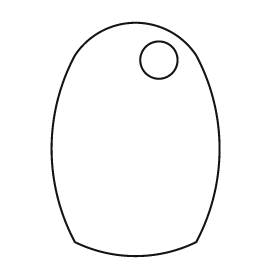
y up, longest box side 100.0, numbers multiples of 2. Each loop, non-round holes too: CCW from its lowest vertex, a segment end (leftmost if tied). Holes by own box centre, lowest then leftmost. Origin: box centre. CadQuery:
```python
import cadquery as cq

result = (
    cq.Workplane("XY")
    .moveTo(-26.0, -44.0)
    .threePointArc((0.0, -50.0), (26.0, -44.0))
    .threePointArc((36.0, -4.0), (26.0, 36.0))
    .threePointArc((0.0, 50.0), (-26.0, 36.0))
    .threePointArc((-36.0, -4.0), (-26.0, -44.0))
    .close()
    .moveTo(10.0, 34.0)
    .circle(8.0)
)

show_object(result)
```